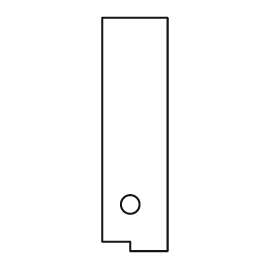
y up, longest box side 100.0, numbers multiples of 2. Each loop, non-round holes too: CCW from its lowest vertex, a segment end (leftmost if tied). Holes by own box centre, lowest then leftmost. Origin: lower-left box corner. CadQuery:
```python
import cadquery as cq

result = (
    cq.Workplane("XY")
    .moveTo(12.0, 0.0)
    .lineTo(28.0, 0.0)
    .lineTo(28.0, 100.0)
    .lineTo(0.0, 100.0)
    .lineTo(0.0, 4.0)
    .lineTo(12.0, 4.0)
    .close()
    .moveTo(12.0, 20.0)
    .circle(4.0)
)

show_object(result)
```